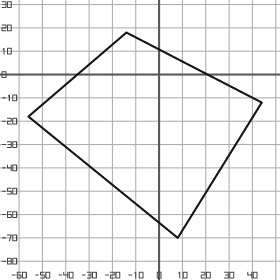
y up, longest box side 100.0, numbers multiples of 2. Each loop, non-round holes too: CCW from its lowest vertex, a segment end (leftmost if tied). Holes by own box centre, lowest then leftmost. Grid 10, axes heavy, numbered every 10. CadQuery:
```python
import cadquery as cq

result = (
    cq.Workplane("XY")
    .moveTo(8.0, -70.0)
    .lineTo(44.0, -12.0)
    .lineTo(-14.0, 18.0)
    .lineTo(-56.0, -18.0)
    .close()
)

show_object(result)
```